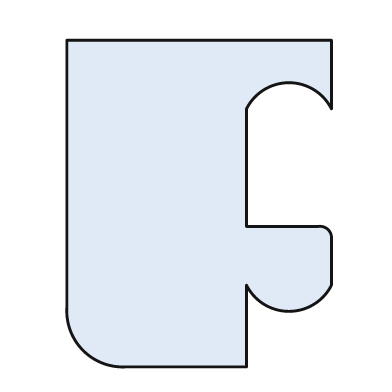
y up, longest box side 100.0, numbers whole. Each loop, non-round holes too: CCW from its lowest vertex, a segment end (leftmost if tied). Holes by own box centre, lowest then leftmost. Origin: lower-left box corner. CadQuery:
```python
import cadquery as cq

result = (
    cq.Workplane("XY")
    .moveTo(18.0, 0.0)
    .lineTo(55.0, 0.0)
    .lineTo(55.0, 25.0)
    .threePointArc((68.0, 17.0), (81.0, 25.0))
    .lineTo(81.0, 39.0)
    .threePointArc((80.0, 42.0), (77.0, 43.0))
    .lineTo(55.0, 43.0)
    .lineTo(55.0, 79.0)
    .threePointArc((68.0, 87.0), (81.0, 79.0))
    .lineTo(81.0, 100.0)
    .lineTo(0.0, 100.0)
    .lineTo(0.0, 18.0)
    .threePointArc((5.0, 5.0), (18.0, 0.0))
    .close()
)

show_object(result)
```